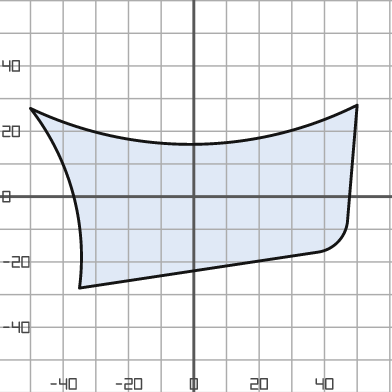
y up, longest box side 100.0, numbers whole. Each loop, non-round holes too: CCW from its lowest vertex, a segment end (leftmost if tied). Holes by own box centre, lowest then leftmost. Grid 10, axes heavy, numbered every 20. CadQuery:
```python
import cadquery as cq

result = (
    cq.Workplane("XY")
    .moveTo(-35.0, -28.0)
    .lineTo(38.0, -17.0)
    .threePointArc((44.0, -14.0), (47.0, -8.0))
    .lineTo(50.0, 28.0)
    .threePointArc((0.0, 16.0), (-50.0, 27.0))
    .threePointArc((-37.0, 1.0), (-35.0, -28.0))
    .close()
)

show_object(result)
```